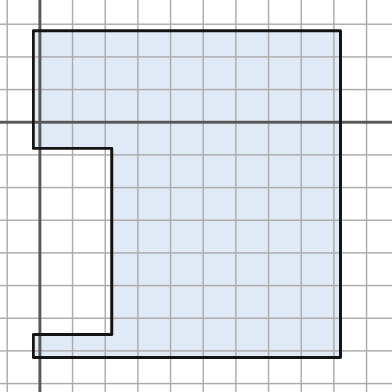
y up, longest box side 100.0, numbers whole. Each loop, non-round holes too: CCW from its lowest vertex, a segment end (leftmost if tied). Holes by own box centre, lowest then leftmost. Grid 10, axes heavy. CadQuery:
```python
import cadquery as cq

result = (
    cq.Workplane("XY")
    .moveTo(-2.0, -72.0)
    .lineTo(92.0, -72.0)
    .lineTo(92.0, 28.0)
    .lineTo(-2.0, 28.0)
    .lineTo(-2.0, -8.0)
    .lineTo(22.0, -8.0)
    .lineTo(22.0, -65.0)
    .lineTo(-2.0, -65.0)
    .close()
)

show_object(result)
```